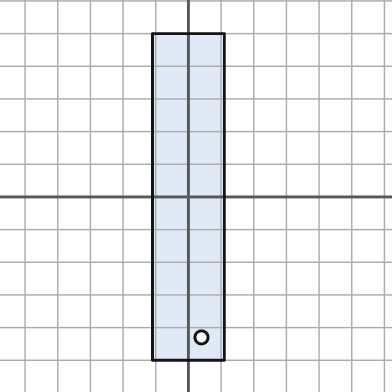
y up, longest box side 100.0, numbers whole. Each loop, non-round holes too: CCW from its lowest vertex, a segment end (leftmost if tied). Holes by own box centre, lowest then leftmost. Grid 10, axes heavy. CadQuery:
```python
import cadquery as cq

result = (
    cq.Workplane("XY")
    .moveTo(-11.0, -50.0)
    .lineTo(11.0, -50.0)
    .lineTo(11.0, 50.0)
    .lineTo(-11.0, 50.0)
    .close()
    .moveTo(4.0, -43.0)
    .circle(2.0)
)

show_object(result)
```